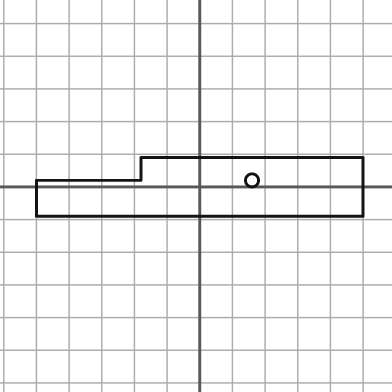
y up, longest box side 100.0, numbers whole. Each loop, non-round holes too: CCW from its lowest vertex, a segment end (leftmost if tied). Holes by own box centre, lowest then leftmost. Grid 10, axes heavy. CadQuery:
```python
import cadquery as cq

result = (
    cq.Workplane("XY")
    .moveTo(-50.0, -9.0)
    .lineTo(50.0, -9.0)
    .lineTo(50.0, 9.0)
    .lineTo(-18.0, 9.0)
    .lineTo(-18.0, 2.0)
    .lineTo(-50.0, 2.0)
    .close()
    .moveTo(16.0, 2.0)
    .circle(2.0)
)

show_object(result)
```